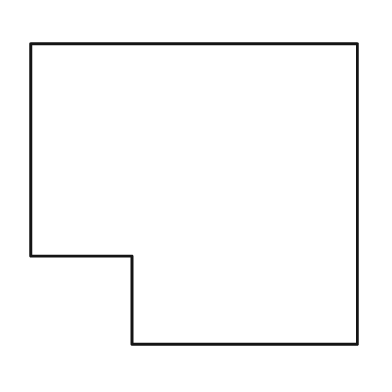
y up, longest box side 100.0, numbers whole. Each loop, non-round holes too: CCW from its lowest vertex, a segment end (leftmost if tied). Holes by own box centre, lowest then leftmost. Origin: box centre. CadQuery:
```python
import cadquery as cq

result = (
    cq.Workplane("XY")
    .moveTo(-19.0, -46.0)
    .lineTo(50.0, -46.0)
    .lineTo(50.0, 46.0)
    .lineTo(-50.0, 46.0)
    .lineTo(-50.0, -19.0)
    .lineTo(-19.0, -19.0)
    .close()
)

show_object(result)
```